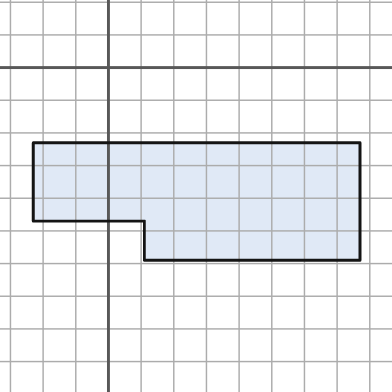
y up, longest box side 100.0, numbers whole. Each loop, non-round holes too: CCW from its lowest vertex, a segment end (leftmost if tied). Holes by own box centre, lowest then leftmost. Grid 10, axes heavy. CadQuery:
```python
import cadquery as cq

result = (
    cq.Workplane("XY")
    .moveTo(11.0, -59.0)
    .lineTo(77.0, -59.0)
    .lineTo(77.0, -23.0)
    .lineTo(-23.0, -23.0)
    .lineTo(-23.0, -47.0)
    .lineTo(11.0, -47.0)
    .close()
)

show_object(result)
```